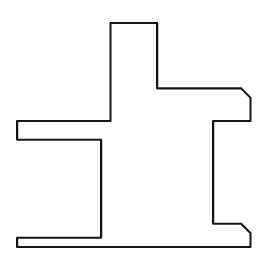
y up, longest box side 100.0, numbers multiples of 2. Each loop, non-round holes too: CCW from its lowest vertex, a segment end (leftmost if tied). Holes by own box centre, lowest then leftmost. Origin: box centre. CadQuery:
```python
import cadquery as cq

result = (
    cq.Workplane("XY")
    .moveTo(-50.0, -48.0)
    .lineTo(50.0, -48.0)
    .lineTo(50.0, -42.0)
    .lineTo(46.0, -38.0)
    .lineTo(34.0, -38.0)
    .lineTo(34.0, 6.0)
    .lineTo(50.0, 6.0)
    .lineTo(50.0, 16.0)
    .lineTo(46.0, 20.0)
    .lineTo(10.0, 20.0)
    .lineTo(10.0, 48.0)
    .lineTo(-10.0, 48.0)
    .lineTo(-10.0, 6.0)
    .lineTo(-50.0, 6.0)
    .lineTo(-50.0, -2.0)
    .lineTo(-14.0, -2.0)
    .lineTo(-14.0, -44.0)
    .lineTo(-50.0, -44.0)
    .close()
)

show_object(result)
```